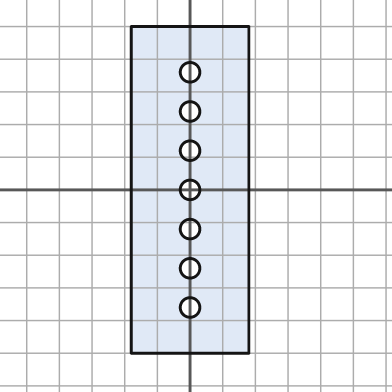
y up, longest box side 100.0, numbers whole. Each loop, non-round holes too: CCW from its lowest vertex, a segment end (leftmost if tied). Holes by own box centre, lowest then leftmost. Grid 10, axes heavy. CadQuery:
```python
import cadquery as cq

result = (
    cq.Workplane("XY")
    .moveTo(-18.0, -50.0)
    .lineTo(18.0, -50.0)
    .lineTo(18.0, 50.0)
    .lineTo(-18.0, 50.0)
    .close()
    .moveTo(0.0, -36.0)
    .circle(3.0)
    .moveTo(0.0, -24.0)
    .circle(3.0)
    .moveTo(0.0, -12.0)
    .circle(3.0)
    .moveTo(0.0, 0.0)
    .circle(3.0)
    .moveTo(0.0, 12.0)
    .circle(3.0)
    .moveTo(0.0, 24.0)
    .circle(3.0)
    .moveTo(0.0, 36.0)
    .circle(3.0)
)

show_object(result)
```